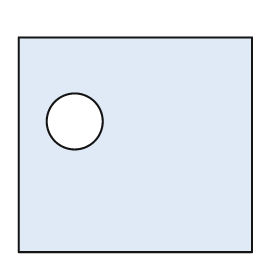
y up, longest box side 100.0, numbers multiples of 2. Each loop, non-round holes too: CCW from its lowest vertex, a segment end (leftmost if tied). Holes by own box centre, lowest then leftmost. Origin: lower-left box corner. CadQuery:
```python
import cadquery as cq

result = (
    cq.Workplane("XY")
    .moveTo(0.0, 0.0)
    .lineTo(100.0, 0.0)
    .lineTo(100.0, 92.0)
    .lineTo(0.0, 92.0)
    .close()
    .moveTo(24.0, 56.0)
    .circle(12.0)
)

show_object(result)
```